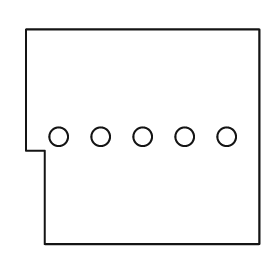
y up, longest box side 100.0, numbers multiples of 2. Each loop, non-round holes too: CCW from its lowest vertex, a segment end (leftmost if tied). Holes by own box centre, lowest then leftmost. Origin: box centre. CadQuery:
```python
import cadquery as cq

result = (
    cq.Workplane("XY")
    .moveTo(-42.0, -46.0)
    .lineTo(50.0, -46.0)
    .lineTo(50.0, 46.0)
    .lineTo(-50.0, 46.0)
    .lineTo(-50.0, -6.0)
    .lineTo(-42.0, -6.0)
    .close()
    .moveTo(-36.0, 0.0)
    .circle(4.0)
    .moveTo(-18.0, 0.0)
    .circle(4.0)
    .moveTo(0.0, 0.0)
    .circle(4.0)
    .moveTo(18.0, 0.0)
    .circle(4.0)
    .moveTo(36.0, 0.0)
    .circle(4.0)
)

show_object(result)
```